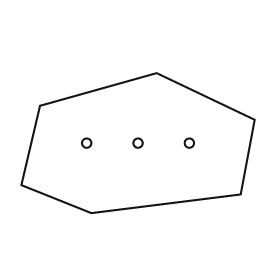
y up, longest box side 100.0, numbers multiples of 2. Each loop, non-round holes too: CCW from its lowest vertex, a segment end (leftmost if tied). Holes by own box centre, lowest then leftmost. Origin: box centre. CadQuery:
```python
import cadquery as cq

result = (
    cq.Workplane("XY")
    .moveTo(-20.0, -30.0)
    .lineTo(44.0, -22.0)
    .lineTo(50.0, 10.0)
    .lineTo(8.0, 30.0)
    .lineTo(-42.0, 16.0)
    .lineTo(-50.0, -18.0)
    .close()
    .moveTo(-22.0, 0.0)
    .circle(2.0)
    .moveTo(0.0, 0.0)
    .circle(2.0)
    .moveTo(22.0, 0.0)
    .circle(2.0)
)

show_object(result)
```